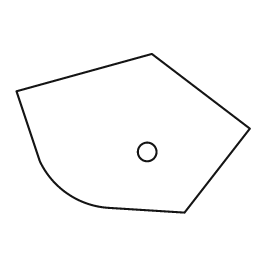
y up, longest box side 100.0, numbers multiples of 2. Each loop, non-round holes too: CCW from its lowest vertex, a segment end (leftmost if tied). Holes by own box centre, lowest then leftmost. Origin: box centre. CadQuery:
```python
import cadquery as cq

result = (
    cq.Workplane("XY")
    .moveTo(22.0, -34.0)
    .lineTo(50.0, 2.0)
    .lineTo(8.0, 34.0)
    .lineTo(-50.0, 18.0)
    .lineTo(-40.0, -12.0)
    .threePointArc((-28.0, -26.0), (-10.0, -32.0))
    .close()
    .moveTo(6.0, -8.0)
    .circle(4.0)
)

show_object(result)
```